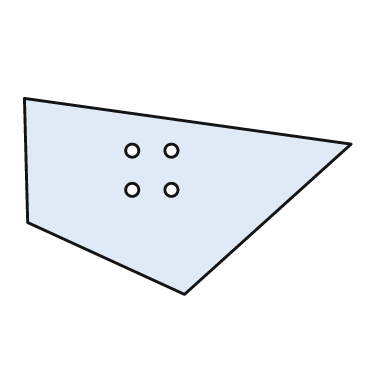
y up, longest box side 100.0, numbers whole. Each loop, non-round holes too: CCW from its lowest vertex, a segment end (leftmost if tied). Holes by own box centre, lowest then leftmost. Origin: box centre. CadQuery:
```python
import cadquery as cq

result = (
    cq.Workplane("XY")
    .moveTo(-1.0, -30.0)
    .lineTo(50.0, 16.0)
    .lineTo(-50.0, 30.0)
    .lineTo(-49.0, -8.0)
    .close()
    .moveTo(-17.0, 2.0)
    .circle(2.0)
    .moveTo(-5.0, 2.0)
    .circle(2.0)
    .moveTo(-17.0, 14.0)
    .circle(2.0)
    .moveTo(-5.0, 14.0)
    .circle(2.0)
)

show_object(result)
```